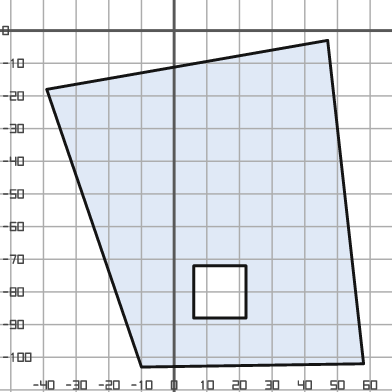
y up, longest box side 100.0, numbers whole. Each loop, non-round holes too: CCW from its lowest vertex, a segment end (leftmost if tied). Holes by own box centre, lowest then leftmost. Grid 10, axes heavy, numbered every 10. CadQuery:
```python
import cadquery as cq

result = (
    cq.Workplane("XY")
    .moveTo(-10.0, -103.0)
    .lineTo(58.0, -102.0)
    .lineTo(47.0, -3.0)
    .lineTo(-39.0, -18.0)
    .close()
    .moveTo(6.0, -88.0)
    .lineTo(22.0, -88.0)
    .lineTo(22.0, -72.0)
    .lineTo(6.0, -72.0)
    .close()
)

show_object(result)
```